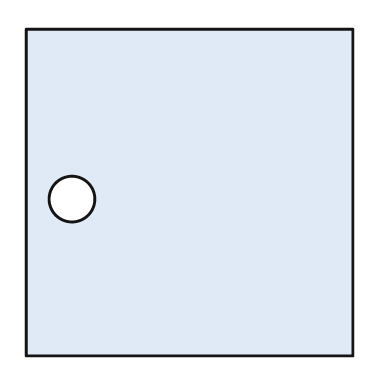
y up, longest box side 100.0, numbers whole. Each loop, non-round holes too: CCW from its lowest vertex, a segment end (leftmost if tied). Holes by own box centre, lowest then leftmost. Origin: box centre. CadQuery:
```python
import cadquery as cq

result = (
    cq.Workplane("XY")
    .moveTo(-50.0, -50.0)
    .lineTo(50.0, -50.0)
    .lineTo(50.0, 50.0)
    .lineTo(-50.0, 50.0)
    .close()
    .moveTo(-36.0, -2.0)
    .circle(7.0)
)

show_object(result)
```